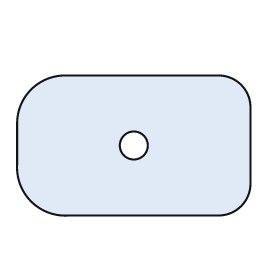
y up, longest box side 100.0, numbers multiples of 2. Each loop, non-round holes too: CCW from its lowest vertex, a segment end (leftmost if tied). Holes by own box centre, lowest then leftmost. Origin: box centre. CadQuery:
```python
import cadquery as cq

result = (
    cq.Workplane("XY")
    .moveTo(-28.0, -30.0)
    .lineTo(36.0, -30.0)
    .threePointArc((46.0, -26.0), (50.0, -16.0))
    .lineTo(50.0, 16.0)
    .threePointArc((46.0, 26.0), (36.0, 30.0))
    .lineTo(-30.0, 30.0)
    .threePointArc((-44.0, 24.0), (-50.0, 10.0))
    .lineTo(-50.0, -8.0)
    .threePointArc((-44.0, -24.0), (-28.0, -30.0))
    .close()
    .moveTo(0.0, 0.0)
    .circle(6.0)
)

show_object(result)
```